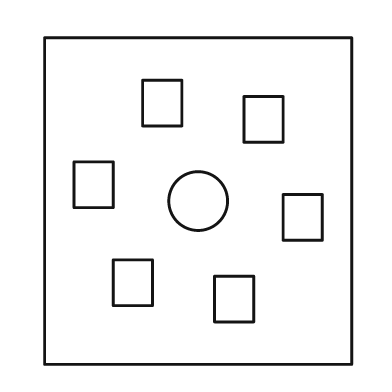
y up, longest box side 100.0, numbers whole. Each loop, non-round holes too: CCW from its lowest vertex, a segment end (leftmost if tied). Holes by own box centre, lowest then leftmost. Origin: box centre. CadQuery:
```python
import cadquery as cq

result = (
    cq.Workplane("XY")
    .moveTo(-47.0, -50.0)
    .lineTo(47.0, -50.0)
    .lineTo(47.0, 50.0)
    .lineTo(-47.0, 50.0)
    .close()
    .moveTo(5.0, -37.0)
    .lineTo(17.0, -37.0)
    .lineTo(17.0, -23.0)
    .lineTo(5.0, -23.0)
    .close()
    .moveTo(-26.0, -32.0)
    .lineTo(-14.0, -32.0)
    .lineTo(-14.0, -18.0)
    .lineTo(-26.0, -18.0)
    .close()
    .moveTo(26.0, -12.0)
    .lineTo(38.0, -12.0)
    .lineTo(38.0, 2.0)
    .lineTo(26.0, 2.0)
    .close()
    .moveTo(0.0, 0.0)
    .circle(9.0)
    .moveTo(-38.0, -2.0)
    .lineTo(-26.0, -2.0)
    .lineTo(-26.0, 12.0)
    .lineTo(-38.0, 12.0)
    .close()
    .moveTo(14.0, 18.0)
    .lineTo(26.0, 18.0)
    .lineTo(26.0, 32.0)
    .lineTo(14.0, 32.0)
    .close()
    .moveTo(-17.0, 23.0)
    .lineTo(-5.0, 23.0)
    .lineTo(-5.0, 37.0)
    .lineTo(-17.0, 37.0)
    .close()
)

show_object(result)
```